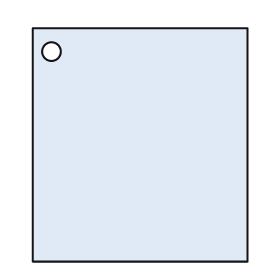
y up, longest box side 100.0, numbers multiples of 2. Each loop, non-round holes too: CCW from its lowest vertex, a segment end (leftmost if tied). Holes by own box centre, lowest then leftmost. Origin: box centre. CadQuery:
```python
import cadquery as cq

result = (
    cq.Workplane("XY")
    .moveTo(-46.0, -50.0)
    .lineTo(46.0, -50.0)
    .lineTo(46.0, 50.0)
    .lineTo(-46.0, 50.0)
    .close()
    .moveTo(-38.0, 40.0)
    .circle(4.0)
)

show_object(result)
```